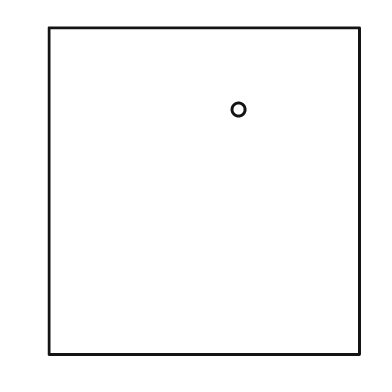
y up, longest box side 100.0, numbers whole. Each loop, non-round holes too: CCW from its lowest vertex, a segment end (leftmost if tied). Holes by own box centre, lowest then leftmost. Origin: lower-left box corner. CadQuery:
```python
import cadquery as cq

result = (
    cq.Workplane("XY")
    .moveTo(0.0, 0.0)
    .lineTo(95.0, 0.0)
    .lineTo(95.0, 100.0)
    .lineTo(0.0, 100.0)
    .close()
    .moveTo(58.0, 75.0)
    .circle(2.0)
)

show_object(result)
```